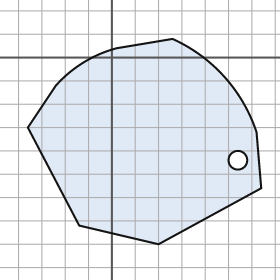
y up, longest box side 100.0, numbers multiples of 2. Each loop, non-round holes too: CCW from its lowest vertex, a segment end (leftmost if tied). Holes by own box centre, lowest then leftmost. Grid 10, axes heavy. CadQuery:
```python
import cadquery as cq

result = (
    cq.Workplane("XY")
    .moveTo(20.0, -80.0)
    .lineTo(64.0, -56.0)
    .lineTo(62.0, -32.0)
    .threePointArc((48.0, -8.0), (26.0, 8.0))
    .lineTo(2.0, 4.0)
    .threePointArc((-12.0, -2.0), (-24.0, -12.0))
    .lineTo(-36.0, -30.0)
    .lineTo(-14.0, -72.0)
    .close()
    .moveTo(54.0, -44.0)
    .circle(4.0)
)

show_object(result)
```